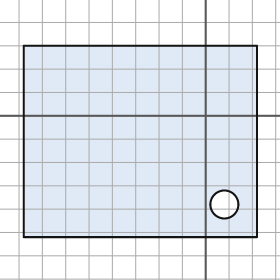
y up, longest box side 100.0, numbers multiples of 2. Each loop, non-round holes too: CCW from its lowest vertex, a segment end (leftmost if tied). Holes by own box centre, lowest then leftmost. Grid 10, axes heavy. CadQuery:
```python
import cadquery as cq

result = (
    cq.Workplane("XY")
    .moveTo(-78.0, -52.0)
    .lineTo(22.0, -52.0)
    .lineTo(22.0, 30.0)
    .lineTo(-78.0, 30.0)
    .close()
    .moveTo(8.0, -38.0)
    .circle(6.0)
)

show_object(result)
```